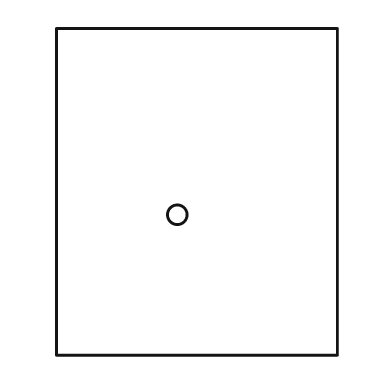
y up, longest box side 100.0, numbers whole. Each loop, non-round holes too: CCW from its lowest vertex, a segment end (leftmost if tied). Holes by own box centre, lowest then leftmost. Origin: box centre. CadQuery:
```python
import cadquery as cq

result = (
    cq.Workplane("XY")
    .moveTo(-43.0, -50.0)
    .lineTo(43.0, -50.0)
    .lineTo(43.0, 50.0)
    .lineTo(-43.0, 50.0)
    .close()
    .moveTo(-6.0, -7.0)
    .circle(3.0)
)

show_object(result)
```